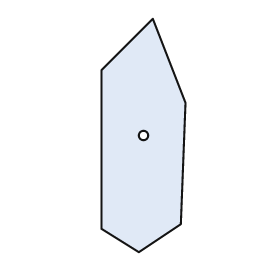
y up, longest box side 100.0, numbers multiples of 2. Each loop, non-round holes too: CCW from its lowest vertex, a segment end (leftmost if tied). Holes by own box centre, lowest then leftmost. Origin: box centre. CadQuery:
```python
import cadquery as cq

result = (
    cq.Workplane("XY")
    .moveTo(-2.0, -50.0)
    .lineTo(16.0, -38.0)
    .lineTo(18.0, 14.0)
    .lineTo(4.0, 50.0)
    .lineTo(-18.0, 28.0)
    .lineTo(-18.0, -40.0)
    .close()
    .moveTo(0.0, 0.0)
    .circle(2.0)
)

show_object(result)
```